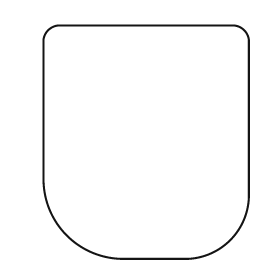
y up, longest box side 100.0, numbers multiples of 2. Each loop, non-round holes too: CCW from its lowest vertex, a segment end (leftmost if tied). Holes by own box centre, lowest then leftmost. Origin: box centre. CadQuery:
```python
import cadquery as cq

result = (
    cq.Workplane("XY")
    .moveTo(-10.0, -50.0)
    .lineTo(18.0, -50.0)
    .threePointArc((36.0, -42.0), (44.0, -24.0))
    .lineTo(44.0, 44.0)
    .threePointArc((42.0, 48.0), (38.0, 50.0))
    .lineTo(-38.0, 50.0)
    .threePointArc((-42.0, 48.0), (-44.0, 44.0))
    .lineTo(-44.0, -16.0)
    .threePointArc((-34.0, -40.0), (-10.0, -50.0))
    .close()
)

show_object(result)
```